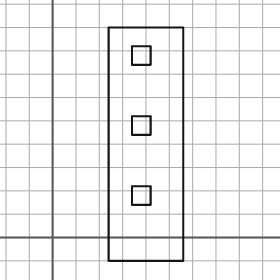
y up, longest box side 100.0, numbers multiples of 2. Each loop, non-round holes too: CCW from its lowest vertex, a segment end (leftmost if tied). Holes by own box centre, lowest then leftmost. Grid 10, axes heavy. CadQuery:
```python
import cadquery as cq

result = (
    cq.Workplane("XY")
    .moveTo(24.0, -10.0)
    .lineTo(56.0, -10.0)
    .lineTo(56.0, 90.0)
    .lineTo(24.0, 90.0)
    .close()
    .moveTo(34.0, 14.0)
    .lineTo(42.0, 14.0)
    .lineTo(42.0, 22.0)
    .lineTo(34.0, 22.0)
    .close()
    .moveTo(34.0, 44.0)
    .lineTo(42.0, 44.0)
    .lineTo(42.0, 52.0)
    .lineTo(34.0, 52.0)
    .close()
    .moveTo(34.0, 74.0)
    .lineTo(42.0, 74.0)
    .lineTo(42.0, 82.0)
    .lineTo(34.0, 82.0)
    .close()
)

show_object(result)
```